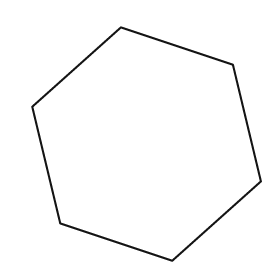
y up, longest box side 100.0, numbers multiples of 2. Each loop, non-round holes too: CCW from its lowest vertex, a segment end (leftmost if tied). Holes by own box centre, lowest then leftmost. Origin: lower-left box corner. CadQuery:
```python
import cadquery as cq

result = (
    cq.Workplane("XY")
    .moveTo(60.0, 0.0)
    .lineTo(98.0, 34.0)
    .lineTo(86.0, 84.0)
    .lineTo(38.0, 100.0)
    .lineTo(0.0, 66.0)
    .lineTo(12.0, 16.0)
    .close()
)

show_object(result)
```